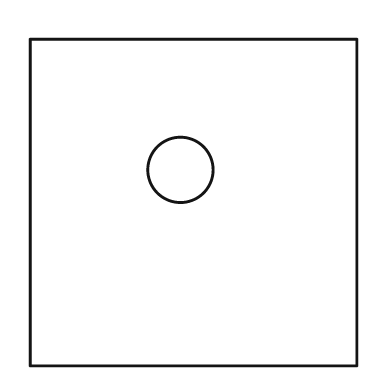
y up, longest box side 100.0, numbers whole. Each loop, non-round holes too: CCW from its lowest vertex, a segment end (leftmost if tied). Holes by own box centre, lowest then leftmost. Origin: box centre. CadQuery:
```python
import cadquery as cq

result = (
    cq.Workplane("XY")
    .moveTo(-50.0, -50.0)
    .lineTo(50.0, -50.0)
    .lineTo(50.0, 50.0)
    .lineTo(-50.0, 50.0)
    .close()
    .moveTo(-4.0, 10.0)
    .circle(10.0)
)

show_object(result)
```